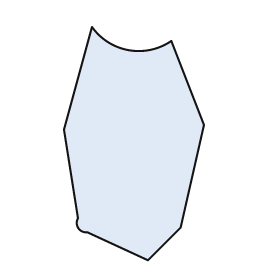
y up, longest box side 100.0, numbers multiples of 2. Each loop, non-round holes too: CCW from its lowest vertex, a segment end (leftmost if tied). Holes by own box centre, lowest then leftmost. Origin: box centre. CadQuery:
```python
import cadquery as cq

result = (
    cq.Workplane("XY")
    .moveTo(6.0, -50.0)
    .lineTo(20.0, -36.0)
    .lineTo(30.0, 8.0)
    .lineTo(16.0, 44.0)
    .threePointArc((-2.0, 40.0), (-18.0, 50.0))
    .lineTo(-30.0, 6.0)
    .lineTo(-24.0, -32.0)
    .threePointArc((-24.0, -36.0), (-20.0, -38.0))
    .close()
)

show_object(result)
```